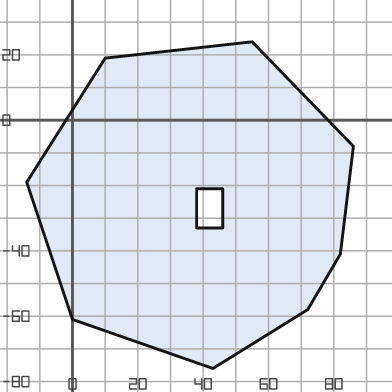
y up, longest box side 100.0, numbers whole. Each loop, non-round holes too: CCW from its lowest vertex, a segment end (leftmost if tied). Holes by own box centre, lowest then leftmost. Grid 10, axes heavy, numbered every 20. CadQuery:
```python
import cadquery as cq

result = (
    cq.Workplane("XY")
    .moveTo(43.0, -76.0)
    .lineTo(72.0, -58.0)
    .lineTo(82.0, -41.0)
    .lineTo(86.0, -8.0)
    .lineTo(55.0, 24.0)
    .lineTo(10.0, 19.0)
    .lineTo(-14.0, -19.0)
    .lineTo(0.0, -61.0)
    .close()
    .moveTo(38.0, -33.0)
    .lineTo(46.0, -33.0)
    .lineTo(46.0, -21.0)
    .lineTo(38.0, -21.0)
    .close()
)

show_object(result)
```